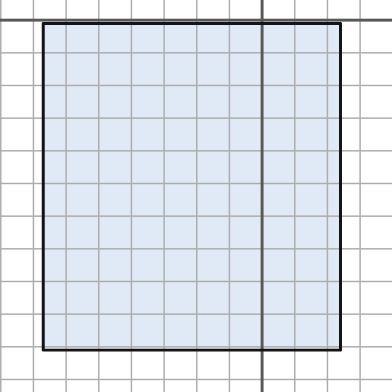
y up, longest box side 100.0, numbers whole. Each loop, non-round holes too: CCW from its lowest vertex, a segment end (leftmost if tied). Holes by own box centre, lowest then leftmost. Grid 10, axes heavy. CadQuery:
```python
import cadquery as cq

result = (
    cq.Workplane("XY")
    .moveTo(-67.0, -101.0)
    .lineTo(24.0, -101.0)
    .lineTo(24.0, -1.0)
    .lineTo(-67.0, -1.0)
    .close()
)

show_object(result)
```